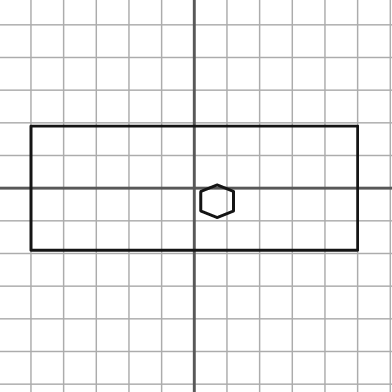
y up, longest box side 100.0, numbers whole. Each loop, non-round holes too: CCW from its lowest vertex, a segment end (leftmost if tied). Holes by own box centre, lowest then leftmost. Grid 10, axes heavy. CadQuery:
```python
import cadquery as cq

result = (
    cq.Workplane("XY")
    .moveTo(-50.0, -19.0)
    .lineTo(50.0, -19.0)
    .lineTo(50.0, 19.0)
    .lineTo(-50.0, 19.0)
    .close()
    .moveTo(7.0, -9.0)
    .lineTo(12.0, -7.0)
    .lineTo(12.0, -1.0)
    .lineTo(7.0, 1.0)
    .lineTo(2.0, -1.0)
    .lineTo(2.0, -7.0)
    .close()
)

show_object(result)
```